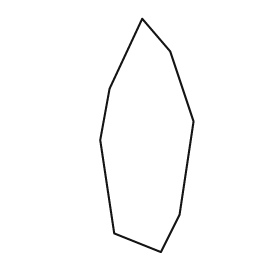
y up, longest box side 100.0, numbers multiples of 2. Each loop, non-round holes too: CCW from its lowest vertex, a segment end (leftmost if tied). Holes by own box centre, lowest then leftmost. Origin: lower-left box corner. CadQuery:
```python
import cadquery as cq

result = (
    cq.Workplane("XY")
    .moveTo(26.0, 0.0)
    .lineTo(34.0, 16.0)
    .lineTo(40.0, 56.0)
    .lineTo(30.0, 86.0)
    .lineTo(18.0, 100.0)
    .lineTo(4.0, 70.0)
    .lineTo(0.0, 48.0)
    .lineTo(6.0, 8.0)
    .close()
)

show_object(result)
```